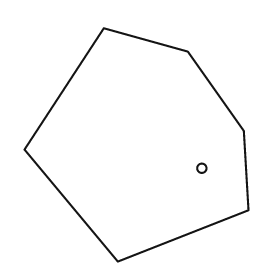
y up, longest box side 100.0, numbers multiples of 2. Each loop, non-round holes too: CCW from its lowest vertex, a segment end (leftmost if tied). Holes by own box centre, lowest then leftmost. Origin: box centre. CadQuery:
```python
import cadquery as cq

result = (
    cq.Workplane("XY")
    .moveTo(-8.0, -50.0)
    .lineTo(48.0, -28.0)
    .lineTo(46.0, 6.0)
    .lineTo(22.0, 40.0)
    .lineTo(-14.0, 50.0)
    .lineTo(-48.0, -2.0)
    .close()
    .moveTo(28.0, -10.0)
    .circle(2.0)
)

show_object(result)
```